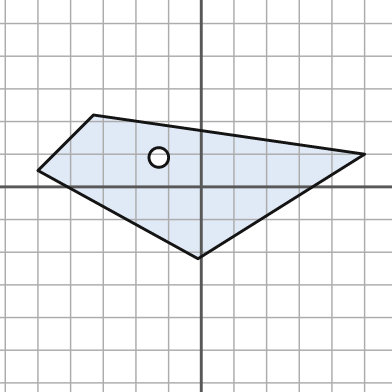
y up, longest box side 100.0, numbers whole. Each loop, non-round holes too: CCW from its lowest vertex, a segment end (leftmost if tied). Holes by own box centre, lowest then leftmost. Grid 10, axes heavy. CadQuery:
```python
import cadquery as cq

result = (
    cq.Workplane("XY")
    .moveTo(-1.0, -22.0)
    .lineTo(50.0, 10.0)
    .lineTo(-33.0, 22.0)
    .lineTo(-50.0, 5.0)
    .close()
    .moveTo(-13.0, 9.0)
    .circle(3.0)
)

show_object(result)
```